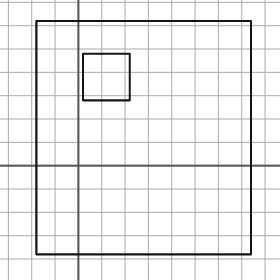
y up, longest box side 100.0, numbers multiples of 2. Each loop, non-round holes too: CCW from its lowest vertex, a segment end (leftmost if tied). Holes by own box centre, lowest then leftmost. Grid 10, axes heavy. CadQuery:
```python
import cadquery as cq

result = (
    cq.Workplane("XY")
    .moveTo(-18.0, -38.0)
    .lineTo(74.0, -38.0)
    .lineTo(74.0, 62.0)
    .lineTo(-18.0, 62.0)
    .close()
    .moveTo(2.0, 28.0)
    .lineTo(22.0, 28.0)
    .lineTo(22.0, 48.0)
    .lineTo(2.0, 48.0)
    .close()
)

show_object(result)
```